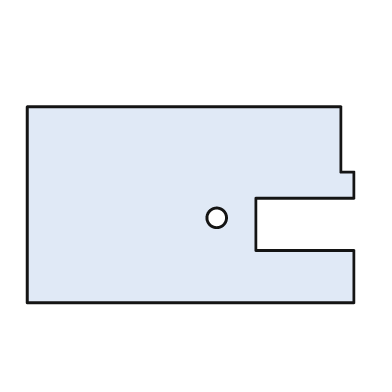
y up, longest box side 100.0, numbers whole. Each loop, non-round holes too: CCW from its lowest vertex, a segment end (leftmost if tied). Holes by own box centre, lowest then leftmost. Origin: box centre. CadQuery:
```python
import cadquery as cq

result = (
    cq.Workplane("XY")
    .moveTo(-50.0, -30.0)
    .lineTo(50.0, -30.0)
    .lineTo(50.0, -14.0)
    .lineTo(20.0, -14.0)
    .lineTo(20.0, 2.0)
    .lineTo(50.0, 2.0)
    .lineTo(50.0, 10.0)
    .lineTo(46.0, 10.0)
    .lineTo(46.0, 30.0)
    .lineTo(-50.0, 30.0)
    .close()
    .moveTo(8.0, -4.0)
    .circle(3.0)
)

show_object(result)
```